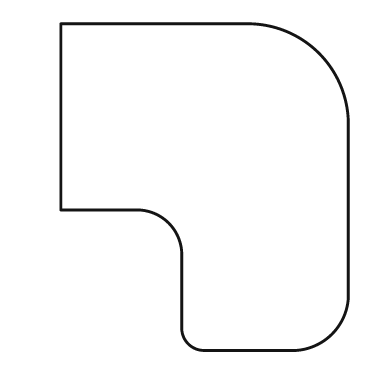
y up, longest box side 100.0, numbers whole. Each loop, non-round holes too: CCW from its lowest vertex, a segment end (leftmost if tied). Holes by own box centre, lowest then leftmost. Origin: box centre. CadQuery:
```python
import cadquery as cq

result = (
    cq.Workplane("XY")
    .moveTo(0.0, -50.0)
    .lineTo(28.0, -50.0)
    .threePointArc((39.0, -45.0), (44.0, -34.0))
    .lineTo(44.0, 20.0)
    .threePointArc((35.0, 41.0), (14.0, 50.0))
    .lineTo(-44.0, 50.0)
    .lineTo(-44.0, -7.0)
    .lineTo(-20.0, -7.0)
    .threePointArc((-11.0, -11.0), (-7.0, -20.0))
    .lineTo(-7.0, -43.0)
    .threePointArc((-5.0, -48.0), (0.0, -50.0))
    .close()
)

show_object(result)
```